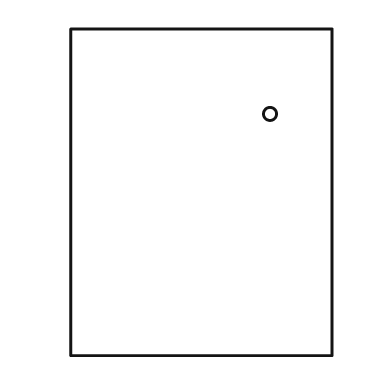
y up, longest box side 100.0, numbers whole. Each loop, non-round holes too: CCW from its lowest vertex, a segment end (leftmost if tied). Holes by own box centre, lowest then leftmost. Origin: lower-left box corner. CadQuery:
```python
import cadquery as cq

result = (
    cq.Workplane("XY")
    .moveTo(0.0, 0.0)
    .lineTo(80.0, 0.0)
    .lineTo(80.0, 100.0)
    .lineTo(0.0, 100.0)
    .close()
    .moveTo(61.0, 74.0)
    .circle(2.0)
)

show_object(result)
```